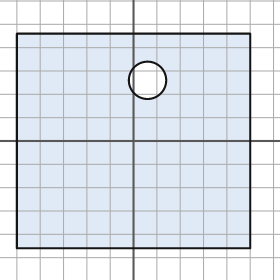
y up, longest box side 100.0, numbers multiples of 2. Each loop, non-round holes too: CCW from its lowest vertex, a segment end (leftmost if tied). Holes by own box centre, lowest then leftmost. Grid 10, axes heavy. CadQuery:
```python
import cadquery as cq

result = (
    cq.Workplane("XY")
    .moveTo(-50.0, -46.0)
    .lineTo(50.0, -46.0)
    .lineTo(50.0, 46.0)
    .lineTo(-50.0, 46.0)
    .close()
    .moveTo(6.0, 26.0)
    .circle(8.0)
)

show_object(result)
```